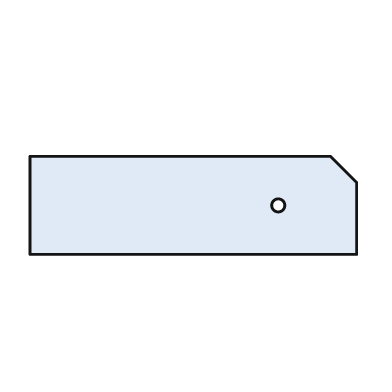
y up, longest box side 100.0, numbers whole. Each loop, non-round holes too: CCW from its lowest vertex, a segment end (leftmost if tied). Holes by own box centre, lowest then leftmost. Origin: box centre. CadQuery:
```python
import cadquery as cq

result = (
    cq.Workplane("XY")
    .moveTo(-50.0, -15.0)
    .lineTo(50.0, -15.0)
    .lineTo(50.0, 7.0)
    .lineTo(42.0, 15.0)
    .lineTo(-50.0, 15.0)
    .close()
    .moveTo(26.0, 0.0)
    .circle(2.0)
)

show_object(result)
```